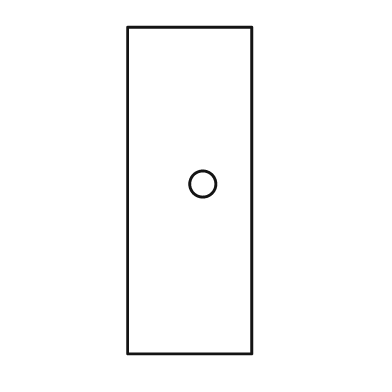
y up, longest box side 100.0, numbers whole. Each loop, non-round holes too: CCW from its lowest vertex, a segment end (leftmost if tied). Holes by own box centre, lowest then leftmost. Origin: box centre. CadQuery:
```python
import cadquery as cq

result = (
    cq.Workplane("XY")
    .moveTo(-19.0, -50.0)
    .lineTo(19.0, -50.0)
    .lineTo(19.0, 50.0)
    .lineTo(-19.0, 50.0)
    .close()
    .moveTo(4.0, 2.0)
    .circle(4.0)
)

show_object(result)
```